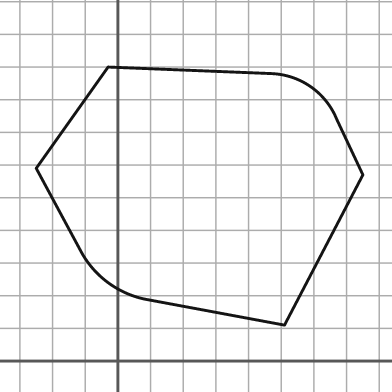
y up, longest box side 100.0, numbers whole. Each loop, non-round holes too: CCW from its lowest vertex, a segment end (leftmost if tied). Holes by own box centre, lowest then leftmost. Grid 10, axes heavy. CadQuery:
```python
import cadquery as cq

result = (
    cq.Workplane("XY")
    .moveTo(51.0, 11.0)
    .lineTo(75.0, 57.0)
    .lineTo(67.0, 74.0)
    .threePointArc((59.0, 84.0), (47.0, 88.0))
    .lineTo(-3.0, 90.0)
    .lineTo(-25.0, 59.0)
    .lineTo(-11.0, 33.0)
    .threePointArc((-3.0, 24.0), (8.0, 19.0))
    .close()
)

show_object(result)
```